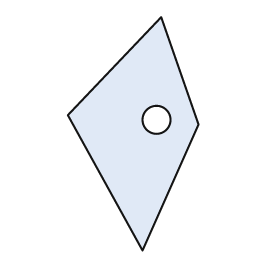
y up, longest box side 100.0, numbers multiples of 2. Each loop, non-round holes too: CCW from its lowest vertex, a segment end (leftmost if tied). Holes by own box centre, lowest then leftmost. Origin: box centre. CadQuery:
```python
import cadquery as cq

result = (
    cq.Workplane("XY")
    .moveTo(4.0, -50.0)
    .lineTo(28.0, 4.0)
    .lineTo(12.0, 50.0)
    .lineTo(-28.0, 8.0)
    .close()
    .moveTo(10.0, 6.0)
    .circle(6.0)
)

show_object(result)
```